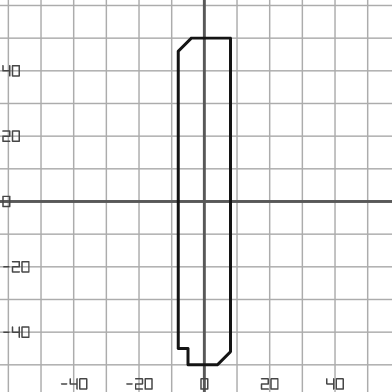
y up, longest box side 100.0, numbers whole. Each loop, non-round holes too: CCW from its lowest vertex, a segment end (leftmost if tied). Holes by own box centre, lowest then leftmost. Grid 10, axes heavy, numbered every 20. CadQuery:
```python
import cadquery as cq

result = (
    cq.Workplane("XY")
    .moveTo(-5.0, -50.0)
    .lineTo(4.0, -50.0)
    .lineTo(8.0, -46.0)
    .lineTo(8.0, 50.0)
    .lineTo(-4.0, 50.0)
    .lineTo(-8.0, 46.0)
    .lineTo(-8.0, -45.0)
    .lineTo(-5.0, -45.0)
    .close()
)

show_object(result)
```